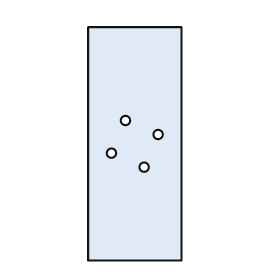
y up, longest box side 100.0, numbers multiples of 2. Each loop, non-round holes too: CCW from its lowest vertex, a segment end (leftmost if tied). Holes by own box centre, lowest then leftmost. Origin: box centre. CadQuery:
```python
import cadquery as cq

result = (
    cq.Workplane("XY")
    .moveTo(-20.0, -50.0)
    .lineTo(20.0, -50.0)
    .lineTo(20.0, 50.0)
    .lineTo(-20.0, 50.0)
    .close()
    .moveTo(4.0, -10.0)
    .circle(2.0)
    .moveTo(-10.0, -4.0)
    .circle(2.0)
    .moveTo(10.0, 4.0)
    .circle(2.0)
    .moveTo(-4.0, 10.0)
    .circle(2.0)
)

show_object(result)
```